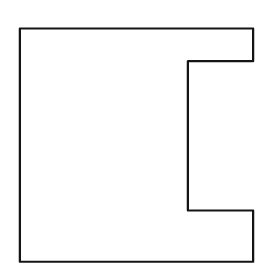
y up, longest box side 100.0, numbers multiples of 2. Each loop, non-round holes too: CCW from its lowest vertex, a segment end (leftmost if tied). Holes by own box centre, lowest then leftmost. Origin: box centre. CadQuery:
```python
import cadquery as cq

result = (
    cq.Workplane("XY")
    .moveTo(-50.0, -50.0)
    .lineTo(50.0, -50.0)
    .lineTo(50.0, -28.0)
    .lineTo(22.0, -28.0)
    .lineTo(22.0, 36.0)
    .lineTo(50.0, 36.0)
    .lineTo(50.0, 50.0)
    .lineTo(-50.0, 50.0)
    .close()
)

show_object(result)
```